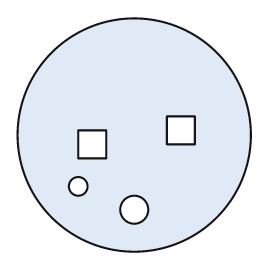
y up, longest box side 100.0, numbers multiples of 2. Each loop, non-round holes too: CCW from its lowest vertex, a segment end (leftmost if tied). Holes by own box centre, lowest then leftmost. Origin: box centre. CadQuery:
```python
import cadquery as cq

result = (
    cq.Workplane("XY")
    .moveTo(0.0, 0.0)
    .circle(50.0)
    .moveTo(0.0, -32.0)
    .circle(6.0)
    .moveTo(-24.0, -22.0)
    .circle(4.0)
    .moveTo(-24.0, -10.0)
    .lineTo(-12.0, -10.0)
    .lineTo(-12.0, 2.0)
    .lineTo(-24.0, 2.0)
    .close()
    .moveTo(14.0, -4.0)
    .lineTo(26.0, -4.0)
    .lineTo(26.0, 8.0)
    .lineTo(14.0, 8.0)
    .close()
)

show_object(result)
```